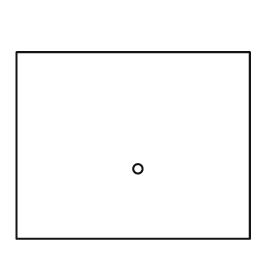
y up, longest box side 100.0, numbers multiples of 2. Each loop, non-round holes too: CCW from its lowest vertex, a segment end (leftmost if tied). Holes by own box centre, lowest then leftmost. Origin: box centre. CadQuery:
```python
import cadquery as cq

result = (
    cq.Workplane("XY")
    .moveTo(-50.0, -40.0)
    .lineTo(50.0, -40.0)
    .lineTo(50.0, 40.0)
    .lineTo(-50.0, 40.0)
    .close()
    .moveTo(2.0, -10.0)
    .circle(2.0)
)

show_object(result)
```